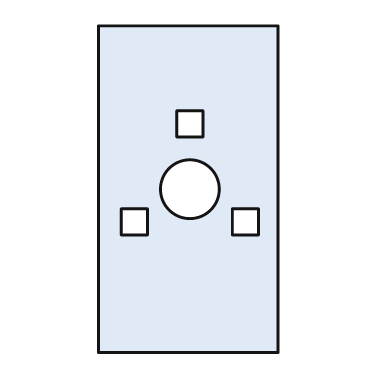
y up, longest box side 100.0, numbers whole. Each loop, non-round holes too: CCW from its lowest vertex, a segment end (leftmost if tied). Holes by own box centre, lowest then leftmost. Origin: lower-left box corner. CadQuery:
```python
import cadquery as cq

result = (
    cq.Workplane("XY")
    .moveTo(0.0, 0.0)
    .lineTo(55.0, 0.0)
    .lineTo(55.0, 100.0)
    .lineTo(0.0, 100.0)
    .close()
    .moveTo(7.0, 36.0)
    .lineTo(15.0, 36.0)
    .lineTo(15.0, 44.0)
    .lineTo(7.0, 44.0)
    .close()
    .moveTo(41.0, 36.0)
    .lineTo(49.0, 36.0)
    .lineTo(49.0, 44.0)
    .lineTo(41.0, 44.0)
    .close()
    .moveTo(28.0, 50.0)
    .circle(9.0)
    .moveTo(24.0, 66.0)
    .lineTo(32.0, 66.0)
    .lineTo(32.0, 74.0)
    .lineTo(24.0, 74.0)
    .close()
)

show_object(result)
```